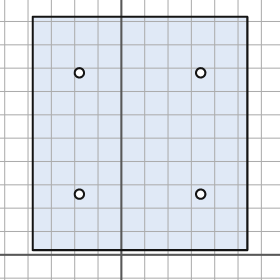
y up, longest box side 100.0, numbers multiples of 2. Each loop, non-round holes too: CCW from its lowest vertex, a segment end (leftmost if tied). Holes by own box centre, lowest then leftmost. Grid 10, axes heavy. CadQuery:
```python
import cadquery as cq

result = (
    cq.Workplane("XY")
    .moveTo(-38.0, 2.0)
    .lineTo(54.0, 2.0)
    .lineTo(54.0, 102.0)
    .lineTo(-38.0, 102.0)
    .close()
    .moveTo(-18.0, 26.0)
    .circle(2.0)
    .moveTo(34.0, 26.0)
    .circle(2.0)
    .moveTo(-18.0, 78.0)
    .circle(2.0)
    .moveTo(34.0, 78.0)
    .circle(2.0)
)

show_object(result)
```